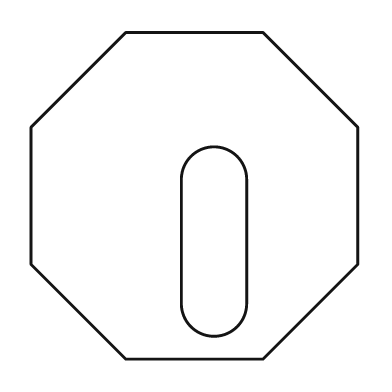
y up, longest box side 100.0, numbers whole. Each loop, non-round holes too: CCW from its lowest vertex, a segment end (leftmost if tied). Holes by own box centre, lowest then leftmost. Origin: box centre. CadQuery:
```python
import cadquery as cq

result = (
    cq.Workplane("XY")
    .moveTo(-21.0, -50.0)
    .lineTo(21.0, -50.0)
    .lineTo(50.0, -21.0)
    .lineTo(50.0, 21.0)
    .lineTo(21.0, 50.0)
    .lineTo(-21.0, 50.0)
    .lineTo(-50.0, 21.0)
    .lineTo(-50.0, -21.0)
    .close()
    .moveTo(-4.0, -33.0)
    .threePointArc((6.0, -43.0), (16.0, -33.0))
    .lineTo(16.0, 5.0)
    .threePointArc((6.0, 15.0), (-4.0, 5.0))
    .close()
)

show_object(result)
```